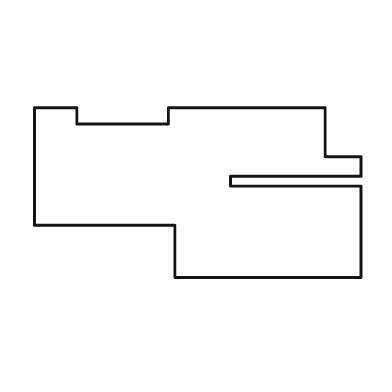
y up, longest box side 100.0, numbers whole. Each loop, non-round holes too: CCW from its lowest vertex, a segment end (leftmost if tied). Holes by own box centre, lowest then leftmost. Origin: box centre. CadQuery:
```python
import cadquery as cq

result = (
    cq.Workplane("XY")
    .moveTo(-7.0, -26.0)
    .lineTo(50.0, -26.0)
    .lineTo(50.0, 2.0)
    .lineTo(10.0, 2.0)
    .lineTo(10.0, 5.0)
    .lineTo(50.0, 5.0)
    .lineTo(50.0, 11.0)
    .lineTo(39.0, 11.0)
    .lineTo(39.0, 26.0)
    .lineTo(-9.0, 26.0)
    .lineTo(-9.0, 21.0)
    .lineTo(-37.0, 21.0)
    .lineTo(-37.0, 26.0)
    .lineTo(-50.0, 26.0)
    .lineTo(-50.0, -10.0)
    .lineTo(-7.0, -10.0)
    .close()
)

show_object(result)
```